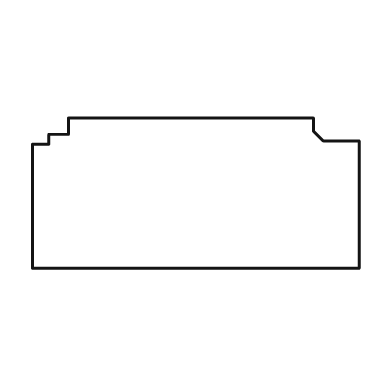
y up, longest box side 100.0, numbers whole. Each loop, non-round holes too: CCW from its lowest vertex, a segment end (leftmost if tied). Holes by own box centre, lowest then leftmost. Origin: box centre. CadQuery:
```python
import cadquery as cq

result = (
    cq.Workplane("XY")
    .moveTo(-50.0, -23.0)
    .lineTo(50.0, -23.0)
    .lineTo(50.0, 16.0)
    .lineTo(39.0, 16.0)
    .lineTo(36.0, 19.0)
    .lineTo(36.0, 23.0)
    .lineTo(-39.0, 23.0)
    .lineTo(-39.0, 18.0)
    .lineTo(-45.0, 18.0)
    .lineTo(-45.0, 15.0)
    .lineTo(-50.0, 15.0)
    .close()
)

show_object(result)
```